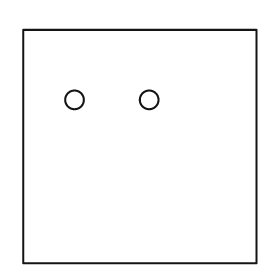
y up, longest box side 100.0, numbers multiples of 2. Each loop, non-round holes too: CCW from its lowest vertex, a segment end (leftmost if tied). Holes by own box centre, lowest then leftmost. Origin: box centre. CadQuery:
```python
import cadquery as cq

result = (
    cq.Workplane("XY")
    .moveTo(-50.0, -50.0)
    .lineTo(50.0, -50.0)
    .lineTo(50.0, 50.0)
    .lineTo(-50.0, 50.0)
    .close()
    .moveTo(-28.0, 20.0)
    .circle(4.0)
    .moveTo(4.0, 20.0)
    .circle(4.0)
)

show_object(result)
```